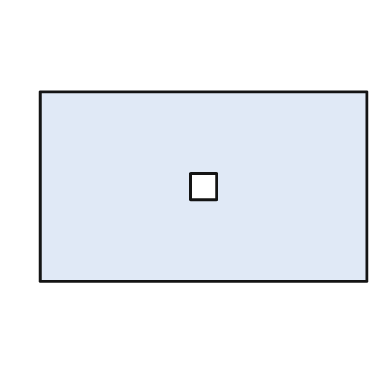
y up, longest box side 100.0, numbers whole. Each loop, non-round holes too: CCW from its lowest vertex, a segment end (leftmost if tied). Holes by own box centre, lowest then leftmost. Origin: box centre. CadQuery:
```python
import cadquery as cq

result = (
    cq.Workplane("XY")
    .moveTo(-50.0, -29.0)
    .lineTo(50.0, -29.0)
    .lineTo(50.0, 29.0)
    .lineTo(-50.0, 29.0)
    .close()
    .moveTo(-4.0, -4.0)
    .lineTo(4.0, -4.0)
    .lineTo(4.0, 4.0)
    .lineTo(-4.0, 4.0)
    .close()
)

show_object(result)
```